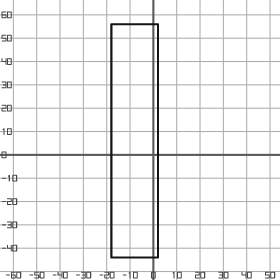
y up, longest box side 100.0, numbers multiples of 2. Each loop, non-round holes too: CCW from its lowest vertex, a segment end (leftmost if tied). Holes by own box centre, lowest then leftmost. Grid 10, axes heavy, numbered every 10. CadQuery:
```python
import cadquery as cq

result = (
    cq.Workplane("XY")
    .moveTo(-18.0, -44.0)
    .lineTo(2.0, -44.0)
    .lineTo(2.0, 56.0)
    .lineTo(-18.0, 56.0)
    .close()
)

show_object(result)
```